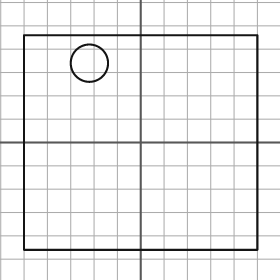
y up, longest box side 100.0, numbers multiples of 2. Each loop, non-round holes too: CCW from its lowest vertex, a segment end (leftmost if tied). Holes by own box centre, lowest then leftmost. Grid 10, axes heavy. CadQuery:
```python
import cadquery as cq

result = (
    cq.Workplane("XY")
    .moveTo(-50.0, -46.0)
    .lineTo(50.0, -46.0)
    .lineTo(50.0, 46.0)
    .lineTo(-50.0, 46.0)
    .close()
    .moveTo(-22.0, 34.0)
    .circle(8.0)
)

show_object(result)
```